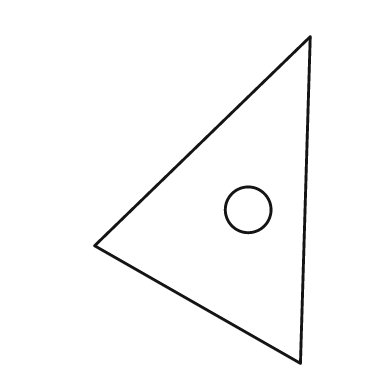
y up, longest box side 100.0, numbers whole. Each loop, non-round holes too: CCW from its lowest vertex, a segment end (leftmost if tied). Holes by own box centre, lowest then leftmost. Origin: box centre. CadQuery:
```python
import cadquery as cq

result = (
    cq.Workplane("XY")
    .moveTo(30.0, -50.0)
    .lineTo(33.0, 50.0)
    .lineTo(-33.0, -14.0)
    .close()
    .moveTo(14.0, -3.0)
    .circle(7.0)
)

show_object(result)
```